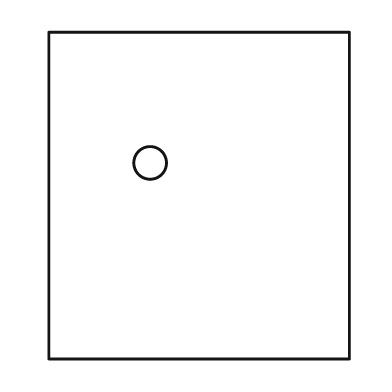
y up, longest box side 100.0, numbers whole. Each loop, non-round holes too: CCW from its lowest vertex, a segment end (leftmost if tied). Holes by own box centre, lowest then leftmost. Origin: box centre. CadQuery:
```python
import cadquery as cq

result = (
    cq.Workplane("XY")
    .moveTo(-46.0, -50.0)
    .lineTo(46.0, -50.0)
    .lineTo(46.0, 50.0)
    .lineTo(-46.0, 50.0)
    .close()
    .moveTo(-15.0, 10.0)
    .circle(5.0)
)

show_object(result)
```